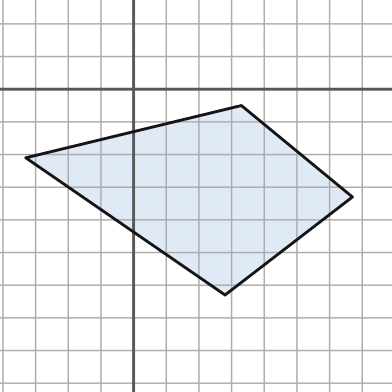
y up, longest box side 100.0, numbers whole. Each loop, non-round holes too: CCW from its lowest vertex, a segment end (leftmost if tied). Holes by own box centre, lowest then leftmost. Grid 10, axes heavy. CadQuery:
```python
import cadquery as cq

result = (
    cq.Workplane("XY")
    .moveTo(28.0, -63.0)
    .lineTo(67.0, -33.0)
    .lineTo(33.0, -5.0)
    .lineTo(-33.0, -21.0)
    .close()
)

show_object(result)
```